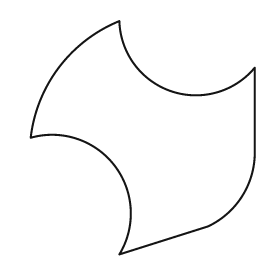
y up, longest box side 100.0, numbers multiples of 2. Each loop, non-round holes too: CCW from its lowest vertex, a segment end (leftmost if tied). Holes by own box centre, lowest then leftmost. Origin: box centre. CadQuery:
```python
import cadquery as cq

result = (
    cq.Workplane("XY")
    .moveTo(-10.0, -50.0)
    .lineTo(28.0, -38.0)
    .threePointArc((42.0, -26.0), (48.0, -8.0))
    .lineTo(48.0, 30.0)
    .threePointArc((12.0, 20.0), (-10.0, 50.0))
    .threePointArc((-36.0, 30.0), (-48.0, 0.0))
    .threePointArc((-12.0, -12.0), (-10.0, -50.0))
    .close()
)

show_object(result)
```